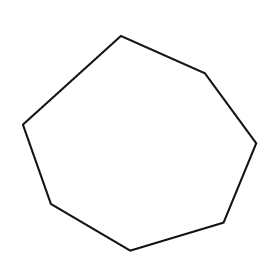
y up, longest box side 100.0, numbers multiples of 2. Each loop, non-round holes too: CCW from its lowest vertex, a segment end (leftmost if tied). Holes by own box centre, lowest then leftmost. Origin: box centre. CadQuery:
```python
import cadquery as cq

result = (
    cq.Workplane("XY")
    .moveTo(-4.0, -46.0)
    .lineTo(36.0, -34.0)
    .lineTo(50.0, 0.0)
    .lineTo(28.0, 30.0)
    .lineTo(-8.0, 46.0)
    .lineTo(-50.0, 8.0)
    .lineTo(-38.0, -26.0)
    .close()
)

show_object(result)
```